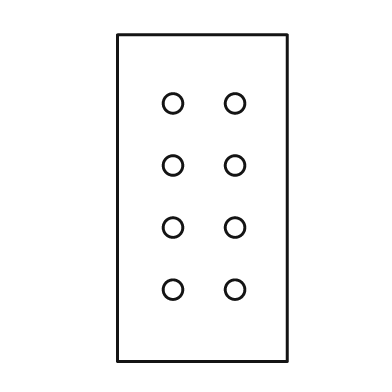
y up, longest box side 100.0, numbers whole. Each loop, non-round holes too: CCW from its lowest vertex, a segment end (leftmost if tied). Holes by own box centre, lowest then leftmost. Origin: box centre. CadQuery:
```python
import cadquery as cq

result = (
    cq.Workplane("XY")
    .moveTo(-26.0, -50.0)
    .lineTo(26.0, -50.0)
    .lineTo(26.0, 50.0)
    .lineTo(-26.0, 50.0)
    .close()
    .moveTo(-9.0, -28.0)
    .circle(3.0)
    .moveTo(10.0, -28.0)
    .circle(3.0)
    .moveTo(-9.0, -9.0)
    .circle(3.0)
    .moveTo(10.0, -9.0)
    .circle(3.0)
    .moveTo(-9.0, 10.0)
    .circle(3.0)
    .moveTo(10.0, 10.0)
    .circle(3.0)
    .moveTo(-9.0, 29.0)
    .circle(3.0)
    .moveTo(10.0, 29.0)
    .circle(3.0)
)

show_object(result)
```